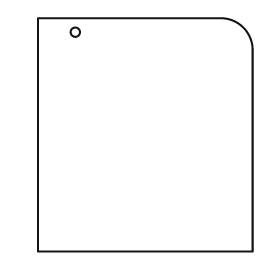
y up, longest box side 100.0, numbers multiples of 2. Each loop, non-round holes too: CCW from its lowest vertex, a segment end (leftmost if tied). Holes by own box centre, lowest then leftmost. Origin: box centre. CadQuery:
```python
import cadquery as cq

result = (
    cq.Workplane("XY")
    .moveTo(-46.0, -50.0)
    .lineTo(46.0, -50.0)
    .lineTo(46.0, 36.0)
    .threePointArc((42.0, 46.0), (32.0, 50.0))
    .lineTo(-46.0, 50.0)
    .close()
    .moveTo(-30.0, 44.0)
    .circle(2.0)
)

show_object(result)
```